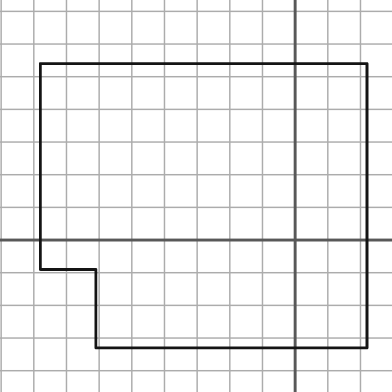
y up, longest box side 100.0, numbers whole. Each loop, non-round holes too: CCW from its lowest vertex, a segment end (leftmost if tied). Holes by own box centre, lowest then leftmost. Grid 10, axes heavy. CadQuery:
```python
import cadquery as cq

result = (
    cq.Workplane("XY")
    .moveTo(-61.0, -33.0)
    .lineTo(22.0, -33.0)
    .lineTo(22.0, 54.0)
    .lineTo(-78.0, 54.0)
    .lineTo(-78.0, -9.0)
    .lineTo(-61.0, -9.0)
    .close()
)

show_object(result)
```